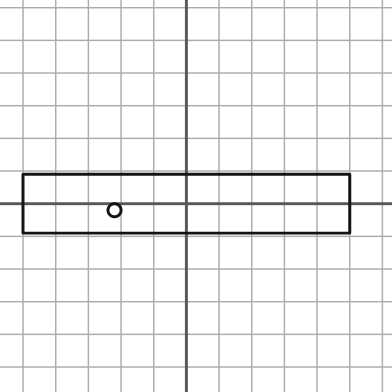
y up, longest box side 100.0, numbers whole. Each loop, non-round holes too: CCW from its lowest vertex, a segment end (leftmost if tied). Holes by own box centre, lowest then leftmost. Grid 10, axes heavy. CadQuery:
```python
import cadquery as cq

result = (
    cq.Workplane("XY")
    .moveTo(-50.0, -9.0)
    .lineTo(50.0, -9.0)
    .lineTo(50.0, 9.0)
    .lineTo(-50.0, 9.0)
    .close()
    .moveTo(-22.0, -2.0)
    .circle(2.0)
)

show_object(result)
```